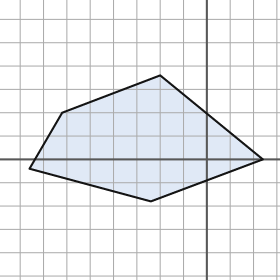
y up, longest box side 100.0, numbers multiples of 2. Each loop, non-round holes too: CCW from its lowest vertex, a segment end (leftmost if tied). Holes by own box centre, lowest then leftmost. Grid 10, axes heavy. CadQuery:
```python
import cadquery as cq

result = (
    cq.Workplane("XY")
    .moveTo(-24.0, -18.0)
    .lineTo(24.0, 0.0)
    .lineTo(-20.0, 36.0)
    .lineTo(-62.0, 20.0)
    .lineTo(-76.0, -4.0)
    .close()
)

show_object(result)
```